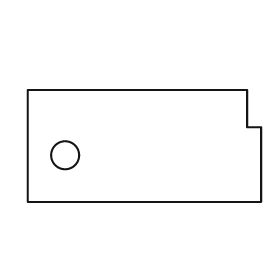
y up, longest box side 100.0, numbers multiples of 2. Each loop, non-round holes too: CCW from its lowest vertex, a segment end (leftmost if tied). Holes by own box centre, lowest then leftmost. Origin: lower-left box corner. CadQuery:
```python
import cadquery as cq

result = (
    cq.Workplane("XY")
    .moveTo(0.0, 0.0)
    .lineTo(100.0, 0.0)
    .lineTo(100.0, 32.0)
    .lineTo(94.0, 32.0)
    .lineTo(94.0, 48.0)
    .lineTo(0.0, 48.0)
    .close()
    .moveTo(16.0, 20.0)
    .circle(6.0)
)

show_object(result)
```